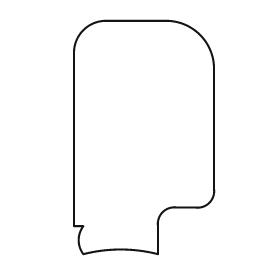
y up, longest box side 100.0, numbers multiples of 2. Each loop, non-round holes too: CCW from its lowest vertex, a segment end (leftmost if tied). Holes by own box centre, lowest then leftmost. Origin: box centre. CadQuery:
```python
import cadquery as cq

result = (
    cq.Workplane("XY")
    .moveTo(-26.0, -50.0)
    .threePointArc((-10.0, -48.0), (6.0, -50.0))
    .lineTo(6.0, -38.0)
    .threePointArc((8.0, -32.0), (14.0, -30.0))
    .lineTo(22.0, -30.0)
    .threePointArc((28.0, -28.0), (30.0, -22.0))
    .lineTo(30.0, 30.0)
    .threePointArc((24.0, 44.0), (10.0, 50.0))
    .lineTo(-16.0, 50.0)
    .threePointArc((-26.0, 46.0), (-30.0, 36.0))
    .lineTo(-30.0, -38.0)
    .lineTo(-26.0, -38.0)
    .threePointArc((-28.0, -44.0), (-26.0, -50.0))
    .close()
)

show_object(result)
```